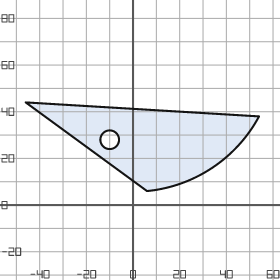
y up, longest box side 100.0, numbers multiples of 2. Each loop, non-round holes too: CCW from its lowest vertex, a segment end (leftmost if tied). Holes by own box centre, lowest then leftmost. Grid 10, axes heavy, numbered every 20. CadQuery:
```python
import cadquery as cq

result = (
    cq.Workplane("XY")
    .moveTo(6.0, 6.0)
    .threePointArc((34.0, 16.0), (54.0, 38.0))
    .lineTo(-46.0, 44.0)
    .close()
    .moveTo(-10.0, 28.0)
    .circle(4.0)
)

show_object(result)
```